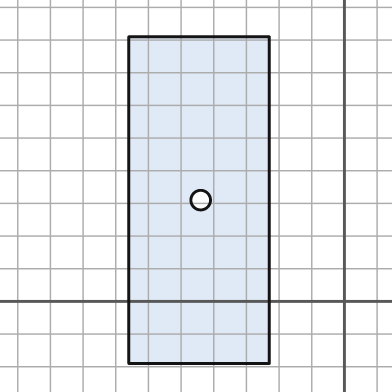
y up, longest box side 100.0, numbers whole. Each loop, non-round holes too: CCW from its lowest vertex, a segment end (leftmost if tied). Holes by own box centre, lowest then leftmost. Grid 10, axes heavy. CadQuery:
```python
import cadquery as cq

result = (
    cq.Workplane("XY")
    .moveTo(-66.0, -19.0)
    .lineTo(-23.0, -19.0)
    .lineTo(-23.0, 81.0)
    .lineTo(-66.0, 81.0)
    .close()
    .moveTo(-44.0, 31.0)
    .circle(3.0)
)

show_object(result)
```